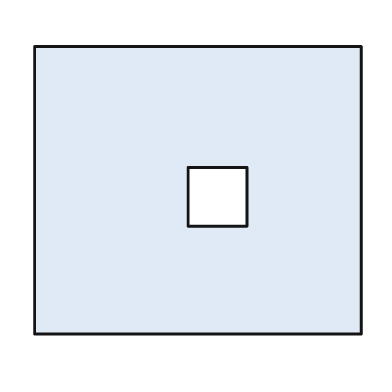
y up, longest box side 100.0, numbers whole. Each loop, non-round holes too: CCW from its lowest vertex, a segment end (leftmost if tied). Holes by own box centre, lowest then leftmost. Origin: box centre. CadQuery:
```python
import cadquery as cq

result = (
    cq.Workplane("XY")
    .moveTo(-50.0, -44.0)
    .lineTo(50.0, -44.0)
    .lineTo(50.0, 44.0)
    .lineTo(-50.0, 44.0)
    .close()
    .moveTo(-3.0, -11.0)
    .lineTo(15.0, -11.0)
    .lineTo(15.0, 7.0)
    .lineTo(-3.0, 7.0)
    .close()
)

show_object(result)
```